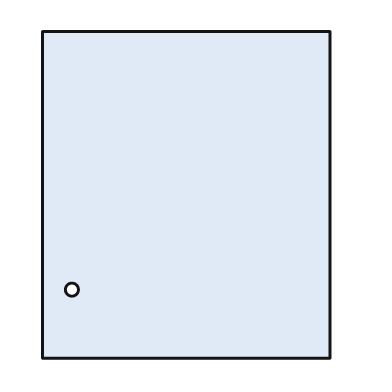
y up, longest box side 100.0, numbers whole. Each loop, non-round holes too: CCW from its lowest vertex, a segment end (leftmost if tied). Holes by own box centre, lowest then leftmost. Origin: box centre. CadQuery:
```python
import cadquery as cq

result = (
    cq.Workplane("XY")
    .moveTo(-44.0, -50.0)
    .lineTo(44.0, -50.0)
    .lineTo(44.0, 50.0)
    .lineTo(-44.0, 50.0)
    .close()
    .moveTo(-35.0, -29.0)
    .circle(2.0)
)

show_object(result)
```